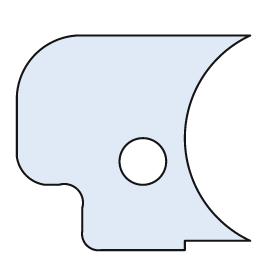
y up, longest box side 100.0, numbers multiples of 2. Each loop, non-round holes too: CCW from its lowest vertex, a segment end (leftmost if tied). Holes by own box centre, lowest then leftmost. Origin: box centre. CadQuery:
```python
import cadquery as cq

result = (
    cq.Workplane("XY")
    .moveTo(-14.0, -46.0)
    .lineTo(22.0, -46.0)
    .lineTo(22.0, -42.0)
    .lineTo(50.0, -42.0)
    .threePointArc((22.0, 2.0), (50.0, 46.0))
    .lineTo(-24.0, 46.0)
    .threePointArc((-42.0, 38.0), (-50.0, 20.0))
    .lineTo(-50.0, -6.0)
    .threePointArc((-46.0, -14.0), (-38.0, -18.0))
    .lineTo(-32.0, -18.0)
    .threePointArc((-24.0, -20.0), (-22.0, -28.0))
    .lineTo(-22.0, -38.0)
    .threePointArc((-20.0, -44.0), (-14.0, -46.0))
    .close()
    .moveTo(4.0, -8.0)
    .circle(10.0)
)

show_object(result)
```